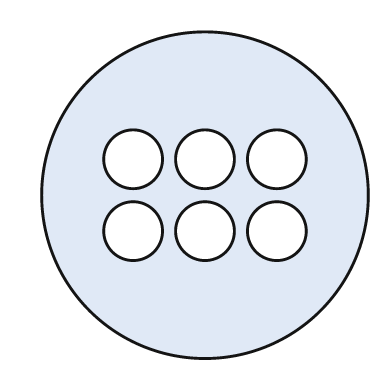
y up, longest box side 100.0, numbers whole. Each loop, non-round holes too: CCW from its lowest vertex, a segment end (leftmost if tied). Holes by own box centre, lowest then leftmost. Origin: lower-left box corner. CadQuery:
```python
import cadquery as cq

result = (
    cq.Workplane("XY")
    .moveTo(50.0, 50.0)
    .circle(50.0)
    .moveTo(28.0, 39.0)
    .circle(9.0)
    .moveTo(50.0, 39.0)
    .circle(9.0)
    .moveTo(72.0, 39.0)
    .circle(9.0)
    .moveTo(28.0, 61.0)
    .circle(9.0)
    .moveTo(50.0, 61.0)
    .circle(9.0)
    .moveTo(72.0, 61.0)
    .circle(9.0)
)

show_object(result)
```